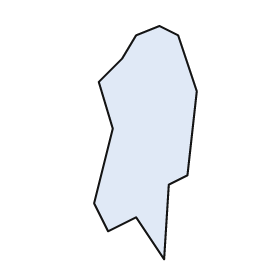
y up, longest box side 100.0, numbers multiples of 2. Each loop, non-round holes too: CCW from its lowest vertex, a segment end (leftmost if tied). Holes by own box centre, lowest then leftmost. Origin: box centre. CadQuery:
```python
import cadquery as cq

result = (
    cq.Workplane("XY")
    .moveTo(8.0, -50.0)
    .lineTo(10.0, -18.0)
    .lineTo(18.0, -14.0)
    .lineTo(22.0, 22.0)
    .lineTo(14.0, 46.0)
    .lineTo(6.0, 50.0)
    .lineTo(-4.0, 46.0)
    .lineTo(-10.0, 36.0)
    .lineTo(-20.0, 26.0)
    .lineTo(-14.0, 6.0)
    .lineTo(-22.0, -26.0)
    .lineTo(-16.0, -38.0)
    .lineTo(-4.0, -32.0)
    .close()
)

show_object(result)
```